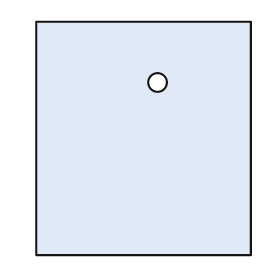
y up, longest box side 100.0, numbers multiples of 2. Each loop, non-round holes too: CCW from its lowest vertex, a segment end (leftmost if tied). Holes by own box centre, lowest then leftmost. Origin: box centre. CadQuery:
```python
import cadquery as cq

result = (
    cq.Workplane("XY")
    .moveTo(-46.0, -50.0)
    .lineTo(46.0, -50.0)
    .lineTo(46.0, 50.0)
    .lineTo(-46.0, 50.0)
    .close()
    .moveTo(6.0, 24.0)
    .circle(4.0)
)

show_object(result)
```